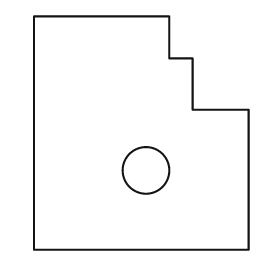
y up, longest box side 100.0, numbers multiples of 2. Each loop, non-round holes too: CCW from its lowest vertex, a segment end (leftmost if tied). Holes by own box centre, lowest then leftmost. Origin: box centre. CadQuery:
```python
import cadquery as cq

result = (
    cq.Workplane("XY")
    .moveTo(-46.0, -50.0)
    .lineTo(46.0, -50.0)
    .lineTo(46.0, 10.0)
    .lineTo(22.0, 10.0)
    .lineTo(22.0, 32.0)
    .lineTo(12.0, 32.0)
    .lineTo(12.0, 50.0)
    .lineTo(-46.0, 50.0)
    .close()
    .moveTo(2.0, -16.0)
    .circle(10.0)
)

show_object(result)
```